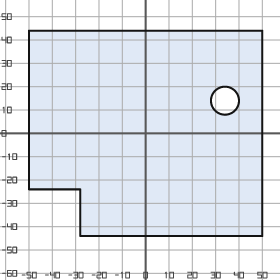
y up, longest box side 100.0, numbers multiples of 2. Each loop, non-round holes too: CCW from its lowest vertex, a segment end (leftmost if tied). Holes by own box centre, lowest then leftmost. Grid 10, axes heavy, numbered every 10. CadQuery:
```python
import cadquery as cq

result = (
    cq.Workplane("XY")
    .moveTo(-28.0, -44.0)
    .lineTo(50.0, -44.0)
    .lineTo(50.0, 44.0)
    .lineTo(-50.0, 44.0)
    .lineTo(-50.0, -24.0)
    .lineTo(-28.0, -24.0)
    .close()
    .moveTo(34.0, 14.0)
    .circle(6.0)
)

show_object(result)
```